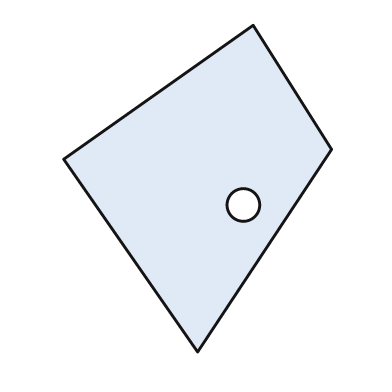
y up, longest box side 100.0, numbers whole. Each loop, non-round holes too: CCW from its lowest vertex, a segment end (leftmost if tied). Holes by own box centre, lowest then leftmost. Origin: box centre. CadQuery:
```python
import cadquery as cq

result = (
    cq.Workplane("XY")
    .moveTo(0.0, -50.0)
    .lineTo(41.0, 12.0)
    .lineTo(17.0, 50.0)
    .lineTo(-41.0, 9.0)
    .close()
    .moveTo(14.0, -5.0)
    .circle(5.0)
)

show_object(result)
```